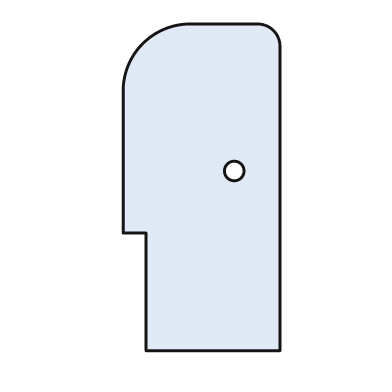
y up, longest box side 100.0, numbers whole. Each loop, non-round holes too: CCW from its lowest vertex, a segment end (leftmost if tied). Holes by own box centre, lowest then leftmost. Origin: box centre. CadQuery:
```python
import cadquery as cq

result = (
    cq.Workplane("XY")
    .moveTo(-17.0, -50.0)
    .lineTo(24.0, -50.0)
    .lineTo(24.0, 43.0)
    .threePointArc((22.0, 48.0), (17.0, 50.0))
    .lineTo(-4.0, 50.0)
    .threePointArc((-18.0, 44.0), (-24.0, 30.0))
    .lineTo(-24.0, -14.0)
    .lineTo(-17.0, -14.0)
    .close()
    .moveTo(10.0, 5.0)
    .circle(3.0)
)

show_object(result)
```